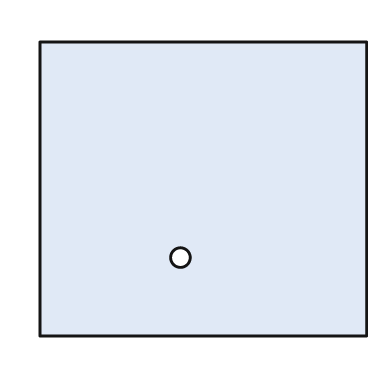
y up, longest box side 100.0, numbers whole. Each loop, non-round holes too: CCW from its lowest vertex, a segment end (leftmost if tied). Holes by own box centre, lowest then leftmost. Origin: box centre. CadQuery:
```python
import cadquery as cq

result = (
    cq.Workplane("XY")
    .moveTo(-50.0, -45.0)
    .lineTo(50.0, -45.0)
    .lineTo(50.0, 45.0)
    .lineTo(-50.0, 45.0)
    .close()
    .moveTo(-7.0, -21.0)
    .circle(3.0)
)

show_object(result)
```